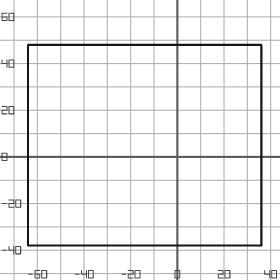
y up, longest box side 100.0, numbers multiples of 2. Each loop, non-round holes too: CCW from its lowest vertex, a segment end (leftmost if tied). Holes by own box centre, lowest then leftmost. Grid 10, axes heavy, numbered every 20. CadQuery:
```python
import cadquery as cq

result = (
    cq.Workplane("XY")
    .moveTo(-64.0, -38.0)
    .lineTo(36.0, -38.0)
    .lineTo(36.0, 48.0)
    .lineTo(-64.0, 48.0)
    .close()
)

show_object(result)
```